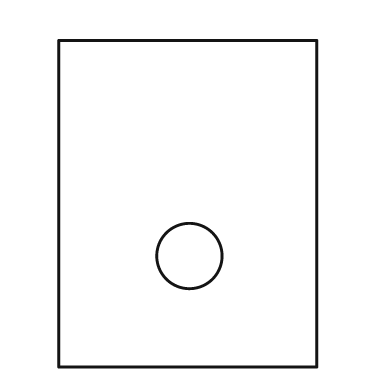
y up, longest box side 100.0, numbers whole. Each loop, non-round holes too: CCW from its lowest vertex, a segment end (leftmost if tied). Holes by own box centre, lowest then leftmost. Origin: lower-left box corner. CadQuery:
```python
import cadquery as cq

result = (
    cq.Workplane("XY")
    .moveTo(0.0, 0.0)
    .lineTo(79.0, 0.0)
    .lineTo(79.0, 100.0)
    .lineTo(0.0, 100.0)
    .close()
    .moveTo(40.0, 34.0)
    .circle(10.0)
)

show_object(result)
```